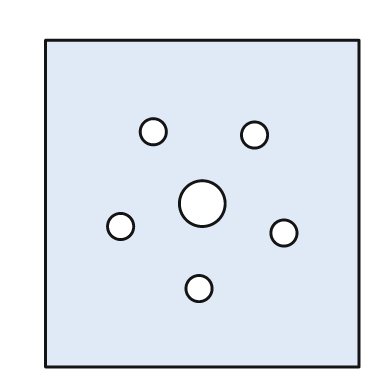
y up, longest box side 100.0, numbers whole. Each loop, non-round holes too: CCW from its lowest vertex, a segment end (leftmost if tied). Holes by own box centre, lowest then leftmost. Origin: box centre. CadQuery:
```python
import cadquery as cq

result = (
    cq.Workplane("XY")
    .moveTo(-48.0, -50.0)
    .lineTo(48.0, -50.0)
    .lineTo(48.0, 50.0)
    .lineTo(-48.0, 50.0)
    .close()
    .moveTo(-1.0, -26.0)
    .circle(4.0)
    .moveTo(25.0, -9.0)
    .circle(4.0)
    .moveTo(-25.0, -7.0)
    .circle(4.0)
    .moveTo(0.0, 0.0)
    .circle(7.0)
    .moveTo(16.0, 21.0)
    .circle(4.0)
    .moveTo(-15.0, 22.0)
    .circle(4.0)
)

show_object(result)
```